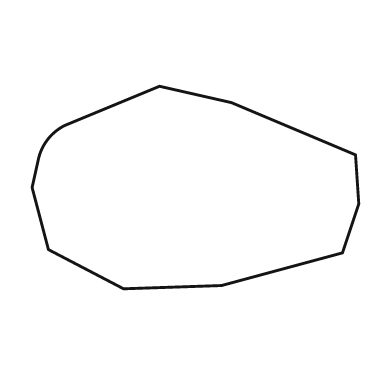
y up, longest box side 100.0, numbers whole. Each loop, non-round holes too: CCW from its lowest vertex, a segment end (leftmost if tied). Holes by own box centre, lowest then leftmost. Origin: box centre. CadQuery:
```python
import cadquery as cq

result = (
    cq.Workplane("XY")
    .moveTo(-22.0, -31.0)
    .lineTo(8.0, -30.0)
    .lineTo(45.0, -20.0)
    .lineTo(50.0, -5.0)
    .lineTo(49.0, 10.0)
    .lineTo(11.0, 26.0)
    .lineTo(-11.0, 31.0)
    .lineTo(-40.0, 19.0)
    .threePointArc((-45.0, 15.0), (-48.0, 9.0))
    .lineTo(-50.0, 0.0)
    .lineTo(-45.0, -19.0)
    .close()
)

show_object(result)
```